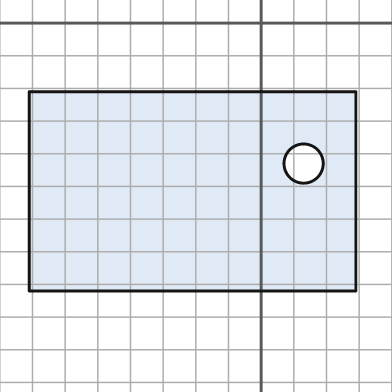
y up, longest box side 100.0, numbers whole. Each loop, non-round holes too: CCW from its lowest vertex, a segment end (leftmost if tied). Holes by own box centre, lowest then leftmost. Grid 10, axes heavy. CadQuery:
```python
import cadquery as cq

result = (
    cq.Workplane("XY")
    .moveTo(-71.0, -82.0)
    .lineTo(29.0, -82.0)
    .lineTo(29.0, -21.0)
    .lineTo(-71.0, -21.0)
    .close()
    .moveTo(13.0, -43.0)
    .circle(6.0)
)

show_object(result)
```